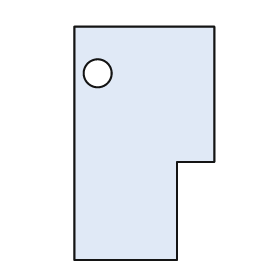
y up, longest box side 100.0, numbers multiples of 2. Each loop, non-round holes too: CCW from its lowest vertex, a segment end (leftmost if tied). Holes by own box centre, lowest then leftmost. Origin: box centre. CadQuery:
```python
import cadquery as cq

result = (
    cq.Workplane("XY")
    .moveTo(-30.0, -50.0)
    .lineTo(14.0, -50.0)
    .lineTo(14.0, -8.0)
    .lineTo(30.0, -8.0)
    .lineTo(30.0, 50.0)
    .lineTo(-30.0, 50.0)
    .close()
    .moveTo(-20.0, 30.0)
    .circle(6.0)
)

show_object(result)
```